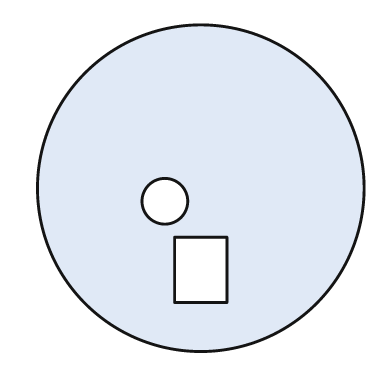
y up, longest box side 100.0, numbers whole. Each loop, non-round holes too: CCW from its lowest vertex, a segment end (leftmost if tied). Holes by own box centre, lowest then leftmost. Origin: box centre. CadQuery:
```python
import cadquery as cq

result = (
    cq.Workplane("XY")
    .moveTo(0.0, 0.0)
    .circle(50.0)
    .moveTo(-8.0, -35.0)
    .lineTo(8.0, -35.0)
    .lineTo(8.0, -15.0)
    .lineTo(-8.0, -15.0)
    .close()
    .moveTo(-11.0, -4.0)
    .circle(7.0)
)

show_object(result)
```